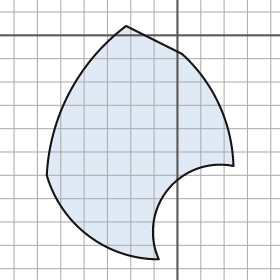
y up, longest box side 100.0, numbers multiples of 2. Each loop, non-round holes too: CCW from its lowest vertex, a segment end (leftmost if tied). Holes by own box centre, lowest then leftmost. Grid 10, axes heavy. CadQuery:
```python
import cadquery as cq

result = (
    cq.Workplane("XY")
    .moveTo(-8.0, -96.0)
    .threePointArc((-4.0, -66.0), (24.0, -56.0))
    .threePointArc((18.0, -30.0), (2.0, -8.0))
    .lineTo(-22.0, 4.0)
    .threePointArc((-46.0, -24.0), (-56.0, -60.0))
    .threePointArc((-38.0, -86.0), (-8.0, -96.0))
    .close()
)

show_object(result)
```